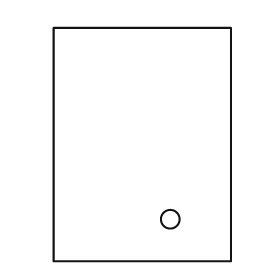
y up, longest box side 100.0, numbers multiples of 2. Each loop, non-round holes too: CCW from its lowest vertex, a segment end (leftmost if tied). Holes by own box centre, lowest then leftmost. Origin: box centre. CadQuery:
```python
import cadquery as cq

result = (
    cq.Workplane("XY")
    .moveTo(-38.0, -50.0)
    .lineTo(38.0, -50.0)
    .lineTo(38.0, 50.0)
    .lineTo(-38.0, 50.0)
    .close()
    .moveTo(12.0, -32.0)
    .circle(4.0)
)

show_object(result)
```